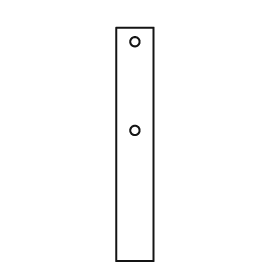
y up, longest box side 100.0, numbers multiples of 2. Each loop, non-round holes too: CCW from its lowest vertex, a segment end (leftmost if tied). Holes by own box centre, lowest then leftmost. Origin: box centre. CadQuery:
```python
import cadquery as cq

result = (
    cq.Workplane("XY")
    .moveTo(-8.0, -50.0)
    .lineTo(8.0, -50.0)
    .lineTo(8.0, 50.0)
    .lineTo(-8.0, 50.0)
    .close()
    .moveTo(0.0, 6.0)
    .circle(2.0)
    .moveTo(0.0, 44.0)
    .circle(2.0)
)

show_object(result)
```